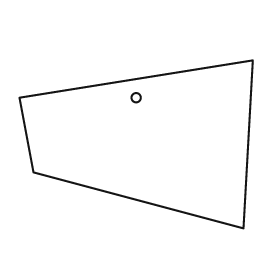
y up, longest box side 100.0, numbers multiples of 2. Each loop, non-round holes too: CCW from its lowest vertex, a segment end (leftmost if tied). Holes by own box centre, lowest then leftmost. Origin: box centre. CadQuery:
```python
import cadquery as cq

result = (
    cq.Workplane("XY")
    .moveTo(46.0, -36.0)
    .lineTo(50.0, 36.0)
    .lineTo(-50.0, 20.0)
    .lineTo(-44.0, -12.0)
    .close()
    .moveTo(0.0, 20.0)
    .circle(2.0)
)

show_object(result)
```